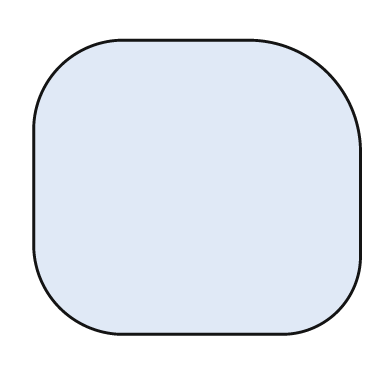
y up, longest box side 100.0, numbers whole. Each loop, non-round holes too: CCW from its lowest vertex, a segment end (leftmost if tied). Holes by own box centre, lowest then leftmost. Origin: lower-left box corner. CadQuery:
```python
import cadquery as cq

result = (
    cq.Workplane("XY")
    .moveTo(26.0, 0.0)
    .lineTo(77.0, 0.0)
    .threePointArc((93.0, 7.0), (100.0, 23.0))
    .lineTo(100.0, 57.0)
    .threePointArc((90.0, 80.0), (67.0, 90.0))
    .lineTo(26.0, 90.0)
    .threePointArc((8.0, 82.0), (0.0, 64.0))
    .lineTo(0.0, 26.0)
    .threePointArc((8.0, 8.0), (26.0, 0.0))
    .close()
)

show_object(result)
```